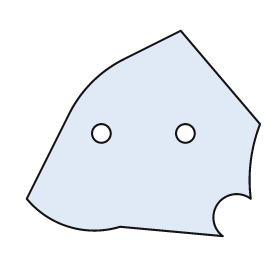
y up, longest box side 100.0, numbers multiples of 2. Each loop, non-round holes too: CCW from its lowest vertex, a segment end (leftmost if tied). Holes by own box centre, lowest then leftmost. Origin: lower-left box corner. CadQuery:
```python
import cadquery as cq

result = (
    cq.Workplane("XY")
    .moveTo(84.0, 0.0)
    .threePointArc((82.0, 14.0), (96.0, 16.0))
    .threePointArc((96.0, 32.0), (100.0, 48.0))
    .lineTo(66.0, 88.0)
    .lineTo(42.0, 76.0)
    .threePointArc((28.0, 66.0), (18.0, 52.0))
    .lineTo(0.0, 16.0)
    .threePointArc((18.0, 4.0), (40.0, 4.0))
    .close()
    .moveTo(32.0, 44.0)
    .circle(4.0)
    .moveTo(68.0, 44.0)
    .circle(4.0)
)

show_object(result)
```